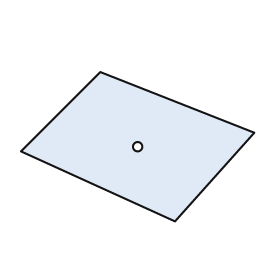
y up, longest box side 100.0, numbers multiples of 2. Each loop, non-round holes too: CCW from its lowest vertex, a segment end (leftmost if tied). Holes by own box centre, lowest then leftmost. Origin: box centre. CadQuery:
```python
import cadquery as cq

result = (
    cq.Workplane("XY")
    .moveTo(16.0, -32.0)
    .lineTo(50.0, 6.0)
    .lineTo(-16.0, 32.0)
    .lineTo(-50.0, -2.0)
    .close()
    .moveTo(0.0, 0.0)
    .circle(2.0)
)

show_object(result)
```